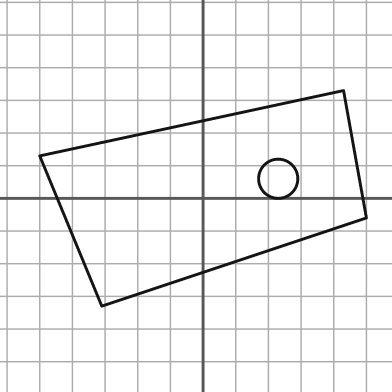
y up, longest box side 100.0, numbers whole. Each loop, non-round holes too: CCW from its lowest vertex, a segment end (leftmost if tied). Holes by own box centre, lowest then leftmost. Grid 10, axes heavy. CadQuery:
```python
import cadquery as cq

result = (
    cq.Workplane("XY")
    .moveTo(-31.0, -33.0)
    .lineTo(50.0, -6.0)
    .lineTo(43.0, 33.0)
    .lineTo(-50.0, 13.0)
    .close()
    .moveTo(23.0, 6.0)
    .circle(6.0)
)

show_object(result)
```